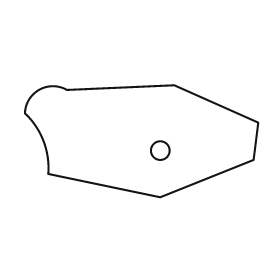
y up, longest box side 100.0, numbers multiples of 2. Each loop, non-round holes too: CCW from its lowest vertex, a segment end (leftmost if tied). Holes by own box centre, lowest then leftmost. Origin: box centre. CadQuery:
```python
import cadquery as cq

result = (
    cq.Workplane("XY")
    .moveTo(8.0, -24.0)
    .lineTo(48.0, -8.0)
    .lineTo(50.0, 8.0)
    .lineTo(14.0, 24.0)
    .lineTo(-32.0, 22.0)
    .threePointArc((-44.0, 22.0), (-50.0, 12.0))
    .threePointArc((-42.0, 0.0), (-40.0, -14.0))
    .close()
    .moveTo(8.0, -4.0)
    .circle(4.0)
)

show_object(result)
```